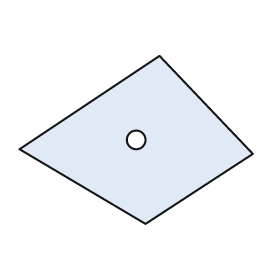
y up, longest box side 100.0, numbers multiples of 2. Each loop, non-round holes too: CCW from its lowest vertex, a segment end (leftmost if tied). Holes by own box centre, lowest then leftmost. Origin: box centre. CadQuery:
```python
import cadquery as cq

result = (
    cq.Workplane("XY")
    .moveTo(4.0, -36.0)
    .lineTo(50.0, -6.0)
    .lineTo(10.0, 36.0)
    .lineTo(-50.0, -4.0)
    .close()
    .moveTo(0.0, 0.0)
    .circle(4.0)
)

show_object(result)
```